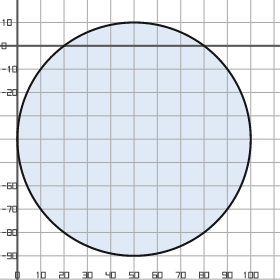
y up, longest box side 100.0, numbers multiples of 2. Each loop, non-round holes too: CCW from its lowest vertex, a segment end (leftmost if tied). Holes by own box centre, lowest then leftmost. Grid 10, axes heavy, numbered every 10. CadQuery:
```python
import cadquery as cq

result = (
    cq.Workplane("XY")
    .moveTo(50.0, -40.0)
    .circle(50.0)
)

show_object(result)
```